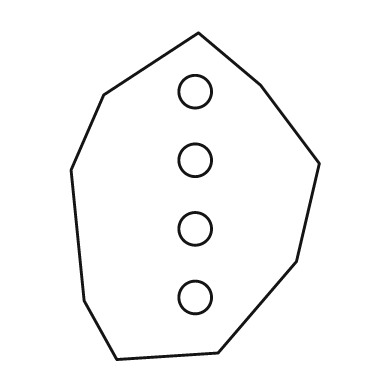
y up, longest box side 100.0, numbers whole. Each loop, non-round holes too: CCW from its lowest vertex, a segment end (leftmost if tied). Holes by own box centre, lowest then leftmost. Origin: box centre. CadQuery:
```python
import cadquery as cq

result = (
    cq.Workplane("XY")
    .moveTo(-24.0, -50.0)
    .lineTo(7.0, -48.0)
    .lineTo(31.0, -20.0)
    .lineTo(38.0, 10.0)
    .lineTo(20.0, 34.0)
    .lineTo(1.0, 50.0)
    .lineTo(-28.0, 31.0)
    .lineTo(-38.0, 8.0)
    .lineTo(-34.0, -32.0)
    .close()
    .moveTo(0.0, -31.0)
    .circle(5.0)
    .moveTo(0.0, -10.0)
    .circle(5.0)
    .moveTo(0.0, 11.0)
    .circle(5.0)
    .moveTo(0.0, 32.0)
    .circle(5.0)
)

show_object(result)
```